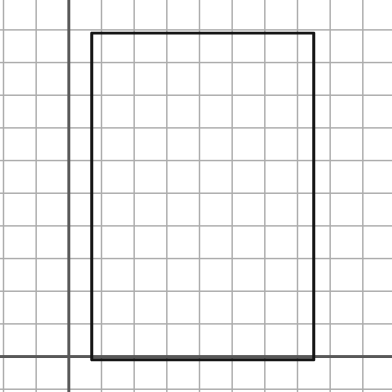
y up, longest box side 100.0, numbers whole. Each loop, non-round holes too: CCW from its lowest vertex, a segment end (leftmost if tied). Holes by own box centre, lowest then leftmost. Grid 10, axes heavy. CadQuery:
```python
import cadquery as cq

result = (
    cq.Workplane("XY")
    .moveTo(7.0, -1.0)
    .lineTo(75.0, -1.0)
    .lineTo(75.0, 99.0)
    .lineTo(7.0, 99.0)
    .close()
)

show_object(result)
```